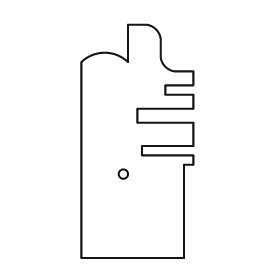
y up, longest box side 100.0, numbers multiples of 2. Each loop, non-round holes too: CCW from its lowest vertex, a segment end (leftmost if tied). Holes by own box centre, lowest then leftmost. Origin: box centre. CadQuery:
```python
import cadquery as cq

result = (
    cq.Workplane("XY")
    .moveTo(-24.0, -50.0)
    .lineTo(20.0, -50.0)
    .lineTo(20.0, -10.0)
    .lineTo(24.0, -10.0)
    .lineTo(24.0, -6.0)
    .lineTo(2.0, -6.0)
    .lineTo(2.0, -2.0)
    .lineTo(24.0, -2.0)
    .lineTo(24.0, 8.0)
    .lineTo(0.0, 8.0)
    .lineTo(0.0, 14.0)
    .lineTo(24.0, 14.0)
    .lineTo(24.0, 20.0)
    .lineTo(12.0, 20.0)
    .lineTo(12.0, 24.0)
    .lineTo(24.0, 24.0)
    .lineTo(24.0, 30.0)
    .lineTo(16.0, 30.0)
    .threePointArc((12.0, 32.0), (10.0, 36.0))
    .lineTo(10.0, 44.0)
    .threePointArc((8.0, 48.0), (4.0, 50.0))
    .lineTo(-4.0, 50.0)
    .lineTo(-4.0, 34.0)
    .threePointArc((-14.0, 38.0), (-24.0, 34.0))
    .close()
    .moveTo(-6.0, -14.0)
    .circle(2.0)
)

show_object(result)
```